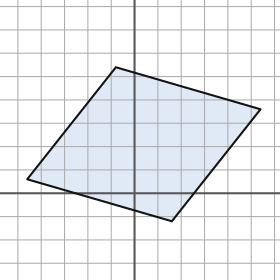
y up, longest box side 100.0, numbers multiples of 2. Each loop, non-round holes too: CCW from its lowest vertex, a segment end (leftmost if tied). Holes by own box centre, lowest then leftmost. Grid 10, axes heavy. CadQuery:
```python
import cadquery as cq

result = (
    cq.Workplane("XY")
    .moveTo(16.0, -12.0)
    .lineTo(54.0, 36.0)
    .lineTo(-8.0, 54.0)
    .lineTo(-46.0, 6.0)
    .close()
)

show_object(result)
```